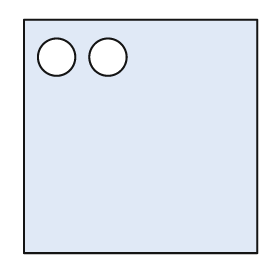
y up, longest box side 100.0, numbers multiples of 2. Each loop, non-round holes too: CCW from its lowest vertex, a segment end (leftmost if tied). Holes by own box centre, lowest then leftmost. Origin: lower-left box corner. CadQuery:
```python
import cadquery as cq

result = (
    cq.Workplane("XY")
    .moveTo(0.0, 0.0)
    .lineTo(100.0, 0.0)
    .lineTo(100.0, 100.0)
    .lineTo(0.0, 100.0)
    .close()
    .moveTo(14.0, 84.0)
    .circle(8.0)
    .moveTo(36.0, 84.0)
    .circle(8.0)
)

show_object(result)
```